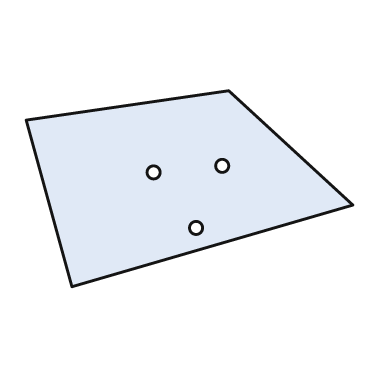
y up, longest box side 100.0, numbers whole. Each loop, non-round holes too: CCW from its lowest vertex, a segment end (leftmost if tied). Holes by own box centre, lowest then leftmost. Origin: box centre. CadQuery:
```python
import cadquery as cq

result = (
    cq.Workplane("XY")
    .moveTo(-36.0, -30.0)
    .lineTo(50.0, -5.0)
    .lineTo(12.0, 30.0)
    .lineTo(-50.0, 21.0)
    .close()
    .moveTo(2.0, -12.0)
    .circle(2.0)
    .moveTo(-11.0, 5.0)
    .circle(2.0)
    .moveTo(10.0, 7.0)
    .circle(2.0)
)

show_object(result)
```